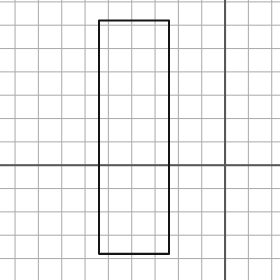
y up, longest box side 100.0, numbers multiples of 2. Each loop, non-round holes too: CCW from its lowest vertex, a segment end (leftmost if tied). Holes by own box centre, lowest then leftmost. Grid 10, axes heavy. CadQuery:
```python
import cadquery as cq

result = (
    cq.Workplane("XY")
    .moveTo(-54.0, -38.0)
    .lineTo(-24.0, -38.0)
    .lineTo(-24.0, 62.0)
    .lineTo(-54.0, 62.0)
    .close()
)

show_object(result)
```